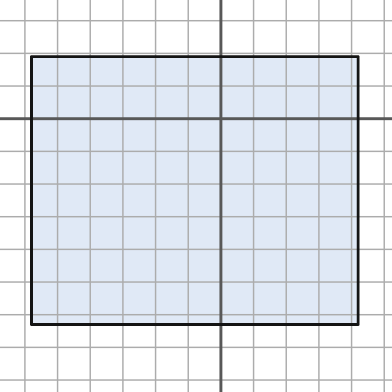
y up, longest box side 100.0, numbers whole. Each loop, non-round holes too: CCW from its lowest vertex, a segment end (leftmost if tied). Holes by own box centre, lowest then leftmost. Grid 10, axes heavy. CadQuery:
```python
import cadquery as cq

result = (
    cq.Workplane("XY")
    .moveTo(-58.0, -63.0)
    .lineTo(42.0, -63.0)
    .lineTo(42.0, 19.0)
    .lineTo(-58.0, 19.0)
    .close()
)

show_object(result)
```